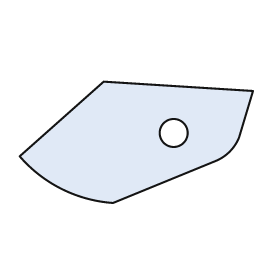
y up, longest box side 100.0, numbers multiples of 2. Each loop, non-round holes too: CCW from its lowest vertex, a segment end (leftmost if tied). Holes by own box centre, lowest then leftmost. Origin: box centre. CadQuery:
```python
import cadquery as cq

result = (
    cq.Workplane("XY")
    .moveTo(-10.0, -26.0)
    .lineTo(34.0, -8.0)
    .threePointArc((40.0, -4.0), (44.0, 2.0))
    .lineTo(50.0, 22.0)
    .lineTo(-14.0, 26.0)
    .lineTo(-50.0, -6.0)
    .threePointArc((-32.0, -20.0), (-10.0, -26.0))
    .close()
    .moveTo(16.0, 4.0)
    .circle(6.0)
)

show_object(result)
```